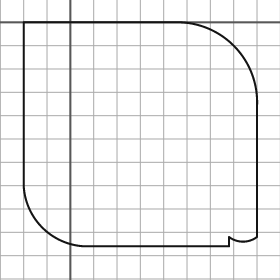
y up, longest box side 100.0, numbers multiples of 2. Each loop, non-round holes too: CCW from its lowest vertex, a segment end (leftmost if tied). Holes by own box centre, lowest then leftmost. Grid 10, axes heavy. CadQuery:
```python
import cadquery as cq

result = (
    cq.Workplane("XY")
    .moveTo(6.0, -96.0)
    .lineTo(68.0, -96.0)
    .lineTo(68.0, -92.0)
    .threePointArc((74.0, -94.0), (80.0, -92.0))
    .lineTo(80.0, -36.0)
    .threePointArc((70.0, -10.0), (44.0, 0.0))
    .lineTo(-20.0, 0.0)
    .lineTo(-20.0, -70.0)
    .threePointArc((-12.0, -88.0), (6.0, -96.0))
    .close()
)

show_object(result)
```